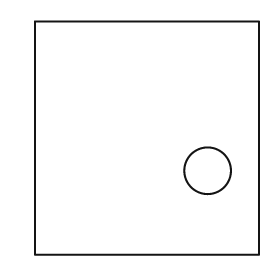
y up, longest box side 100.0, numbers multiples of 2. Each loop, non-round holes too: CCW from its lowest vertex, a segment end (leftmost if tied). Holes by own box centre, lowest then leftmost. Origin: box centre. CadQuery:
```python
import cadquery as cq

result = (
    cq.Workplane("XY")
    .moveTo(-48.0, -50.0)
    .lineTo(48.0, -50.0)
    .lineTo(48.0, 50.0)
    .lineTo(-48.0, 50.0)
    .close()
    .moveTo(26.0, -14.0)
    .circle(10.0)
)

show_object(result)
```